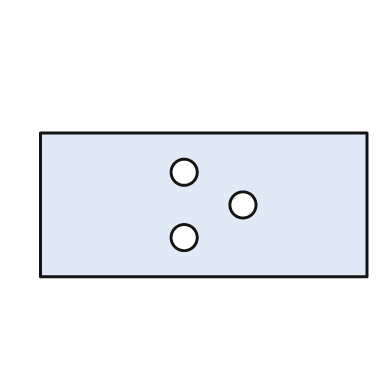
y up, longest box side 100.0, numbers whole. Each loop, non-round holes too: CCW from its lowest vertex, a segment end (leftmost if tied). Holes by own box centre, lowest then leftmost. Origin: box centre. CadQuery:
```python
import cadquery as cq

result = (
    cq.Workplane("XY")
    .moveTo(-50.0, -22.0)
    .lineTo(50.0, -22.0)
    .lineTo(50.0, 22.0)
    .lineTo(-50.0, 22.0)
    .close()
    .moveTo(-6.0, -10.0)
    .circle(4.0)
    .moveTo(12.0, 0.0)
    .circle(4.0)
    .moveTo(-6.0, 10.0)
    .circle(4.0)
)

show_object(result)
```